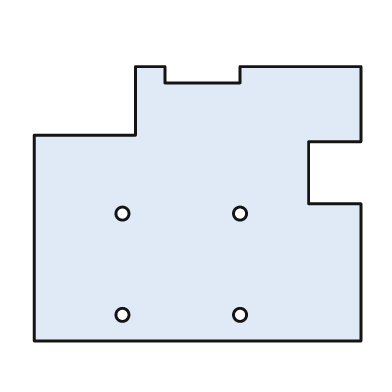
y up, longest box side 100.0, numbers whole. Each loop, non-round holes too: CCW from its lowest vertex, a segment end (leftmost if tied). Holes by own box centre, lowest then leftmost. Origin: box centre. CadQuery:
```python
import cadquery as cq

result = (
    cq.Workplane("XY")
    .moveTo(-50.0, -42.0)
    .lineTo(50.0, -42.0)
    .lineTo(50.0, 0.0)
    .lineTo(34.0, 0.0)
    .lineTo(34.0, 19.0)
    .lineTo(50.0, 19.0)
    .lineTo(50.0, 42.0)
    .lineTo(13.0, 42.0)
    .lineTo(13.0, 37.0)
    .lineTo(-10.0, 37.0)
    .lineTo(-10.0, 42.0)
    .lineTo(-19.0, 42.0)
    .lineTo(-19.0, 21.0)
    .lineTo(-50.0, 21.0)
    .close()
    .moveTo(-23.0, -34.0)
    .circle(2.0)
    .moveTo(13.0, -34.0)
    .circle(2.0)
    .moveTo(-23.0, -3.0)
    .circle(2.0)
    .moveTo(13.0, -3.0)
    .circle(2.0)
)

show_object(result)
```